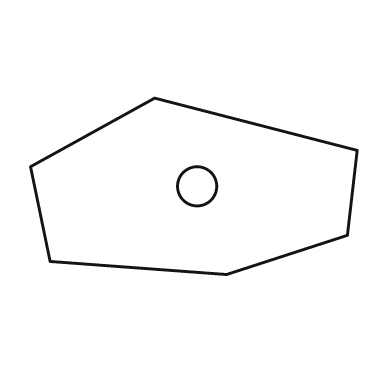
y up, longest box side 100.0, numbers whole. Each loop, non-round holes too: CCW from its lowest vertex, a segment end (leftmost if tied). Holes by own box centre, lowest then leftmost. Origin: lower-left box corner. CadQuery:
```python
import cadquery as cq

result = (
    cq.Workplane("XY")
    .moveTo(60.0, 0.0)
    .lineTo(97.0, 12.0)
    .lineTo(100.0, 38.0)
    .lineTo(38.0, 54.0)
    .lineTo(0.0, 33.0)
    .lineTo(6.0, 4.0)
    .close()
    .moveTo(51.0, 27.0)
    .circle(6.0)
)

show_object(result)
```